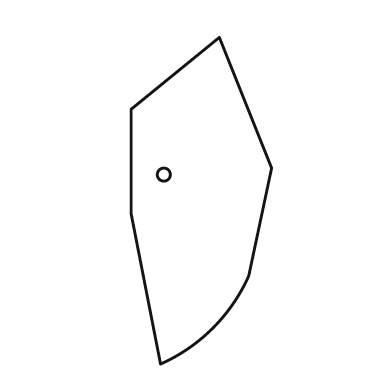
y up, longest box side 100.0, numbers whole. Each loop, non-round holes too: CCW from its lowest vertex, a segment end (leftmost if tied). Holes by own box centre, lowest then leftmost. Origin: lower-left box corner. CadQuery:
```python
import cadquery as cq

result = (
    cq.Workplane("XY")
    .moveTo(9.0, 0.0)
    .threePointArc((25.0, 11.0), (36.0, 27.0))
    .lineTo(43.0, 60.0)
    .lineTo(27.0, 100.0)
    .lineTo(0.0, 78.0)
    .lineTo(0.0, 46.0)
    .close()
    .moveTo(10.0, 58.0)
    .circle(2.0)
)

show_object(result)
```